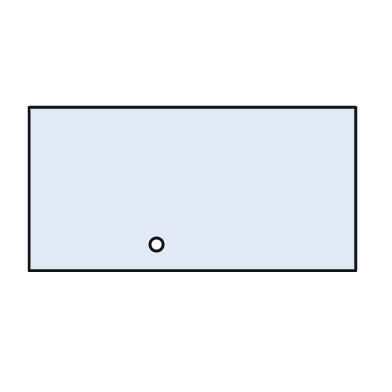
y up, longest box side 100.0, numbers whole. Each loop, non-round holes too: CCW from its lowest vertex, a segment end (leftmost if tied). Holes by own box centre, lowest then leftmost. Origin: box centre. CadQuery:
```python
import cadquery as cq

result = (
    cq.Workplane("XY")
    .moveTo(-50.0, -25.0)
    .lineTo(50.0, -25.0)
    .lineTo(50.0, 25.0)
    .lineTo(-50.0, 25.0)
    .close()
    .moveTo(-11.0, -17.0)
    .circle(2.0)
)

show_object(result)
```